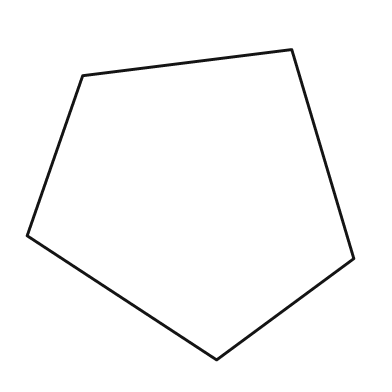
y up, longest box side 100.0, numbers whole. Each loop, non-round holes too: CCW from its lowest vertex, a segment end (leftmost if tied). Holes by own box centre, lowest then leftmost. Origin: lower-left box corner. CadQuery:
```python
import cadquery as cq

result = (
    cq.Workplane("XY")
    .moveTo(58.0, 0.0)
    .lineTo(100.0, 31.0)
    .lineTo(81.0, 95.0)
    .lineTo(17.0, 87.0)
    .lineTo(0.0, 38.0)
    .close()
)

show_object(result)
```